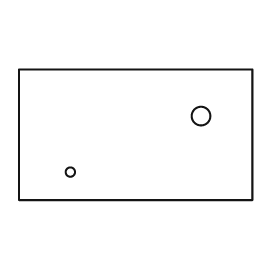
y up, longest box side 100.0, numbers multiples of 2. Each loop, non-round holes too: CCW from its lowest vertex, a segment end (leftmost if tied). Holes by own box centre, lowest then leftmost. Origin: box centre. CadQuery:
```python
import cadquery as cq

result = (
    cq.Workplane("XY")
    .moveTo(-50.0, -28.0)
    .lineTo(50.0, -28.0)
    .lineTo(50.0, 28.0)
    .lineTo(-50.0, 28.0)
    .close()
    .moveTo(-28.0, -16.0)
    .circle(2.0)
    .moveTo(28.0, 8.0)
    .circle(4.0)
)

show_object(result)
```